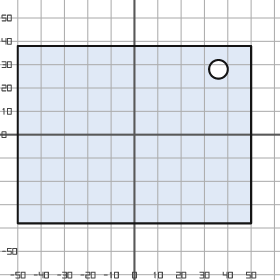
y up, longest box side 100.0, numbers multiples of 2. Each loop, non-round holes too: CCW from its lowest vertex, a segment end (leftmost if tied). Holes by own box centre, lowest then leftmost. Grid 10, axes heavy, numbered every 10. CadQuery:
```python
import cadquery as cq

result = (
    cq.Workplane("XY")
    .moveTo(-50.0, -38.0)
    .lineTo(50.0, -38.0)
    .lineTo(50.0, 38.0)
    .lineTo(-50.0, 38.0)
    .close()
    .moveTo(36.0, 28.0)
    .circle(4.0)
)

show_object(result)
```